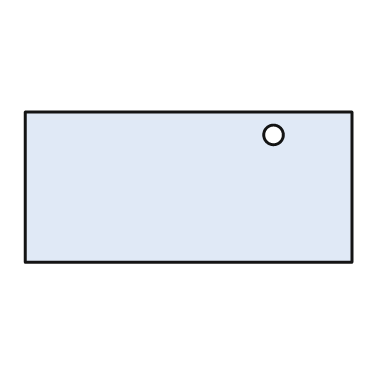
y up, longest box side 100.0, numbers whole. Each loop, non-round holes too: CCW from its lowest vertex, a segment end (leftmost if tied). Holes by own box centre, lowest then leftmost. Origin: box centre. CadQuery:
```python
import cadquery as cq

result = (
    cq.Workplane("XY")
    .moveTo(-50.0, -23.0)
    .lineTo(50.0, -23.0)
    .lineTo(50.0, 23.0)
    .lineTo(-50.0, 23.0)
    .close()
    .moveTo(26.0, 16.0)
    .circle(3.0)
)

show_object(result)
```